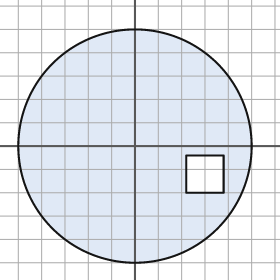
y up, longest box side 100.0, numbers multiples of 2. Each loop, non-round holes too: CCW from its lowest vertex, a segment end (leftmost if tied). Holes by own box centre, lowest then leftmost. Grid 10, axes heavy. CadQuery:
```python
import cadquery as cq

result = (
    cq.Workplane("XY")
    .moveTo(0.0, 0.0)
    .circle(50.0)
    .moveTo(22.0, -20.0)
    .lineTo(38.0, -20.0)
    .lineTo(38.0, -4.0)
    .lineTo(22.0, -4.0)
    .close()
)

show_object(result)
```